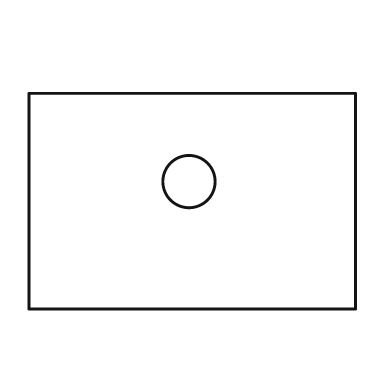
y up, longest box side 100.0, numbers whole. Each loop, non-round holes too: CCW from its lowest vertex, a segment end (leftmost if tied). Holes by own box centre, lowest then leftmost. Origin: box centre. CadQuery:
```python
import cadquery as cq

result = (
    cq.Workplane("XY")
    .moveTo(-50.0, -33.0)
    .lineTo(50.0, -33.0)
    .lineTo(50.0, 33.0)
    .lineTo(-50.0, 33.0)
    .close()
    .moveTo(-1.0, 6.0)
    .circle(8.0)
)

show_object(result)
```